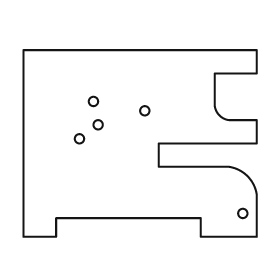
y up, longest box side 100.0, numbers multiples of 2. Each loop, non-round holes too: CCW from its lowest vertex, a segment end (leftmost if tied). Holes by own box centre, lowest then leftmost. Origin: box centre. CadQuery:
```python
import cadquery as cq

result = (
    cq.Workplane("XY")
    .moveTo(-50.0, -40.0)
    .lineTo(-36.0, -40.0)
    .lineTo(-36.0, -32.0)
    .lineTo(26.0, -32.0)
    .lineTo(26.0, -40.0)
    .lineTo(50.0, -40.0)
    .lineTo(50.0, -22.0)
    .threePointArc((46.0, -14.0), (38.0, -10.0))
    .lineTo(8.0, -10.0)
    .lineTo(8.0, 0.0)
    .lineTo(50.0, 0.0)
    .lineTo(50.0, 10.0)
    .lineTo(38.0, 10.0)
    .threePointArc((34.0, 12.0), (32.0, 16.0))
    .lineTo(32.0, 30.0)
    .lineTo(50.0, 30.0)
    .lineTo(50.0, 40.0)
    .lineTo(-50.0, 40.0)
    .close()
    .moveTo(44.0, -30.0)
    .circle(2.0)
    .moveTo(-26.0, 2.0)
    .circle(2.0)
    .moveTo(-18.0, 8.0)
    .circle(2.0)
    .moveTo(2.0, 14.0)
    .circle(2.0)
    .moveTo(-20.0, 18.0)
    .circle(2.0)
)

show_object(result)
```